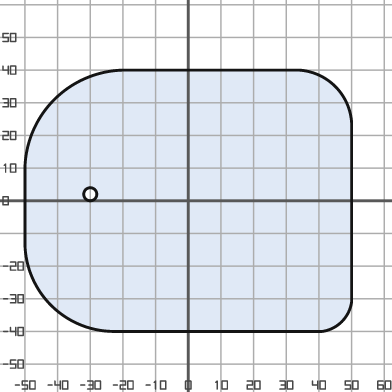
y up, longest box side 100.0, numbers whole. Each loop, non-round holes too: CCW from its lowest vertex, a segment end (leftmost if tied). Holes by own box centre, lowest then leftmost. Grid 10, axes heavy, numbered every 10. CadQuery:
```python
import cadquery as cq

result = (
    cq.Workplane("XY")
    .moveTo(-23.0, -40.0)
    .lineTo(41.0, -40.0)
    .threePointArc((47.0, -37.0), (50.0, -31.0))
    .lineTo(50.0, 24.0)
    .threePointArc((45.0, 35.0), (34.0, 40.0))
    .lineTo(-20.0, 40.0)
    .threePointArc((-41.0, 31.0), (-50.0, 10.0))
    .lineTo(-50.0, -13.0)
    .threePointArc((-42.0, -32.0), (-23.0, -40.0))
    .close()
    .moveTo(-30.0, 2.0)
    .circle(2.0)
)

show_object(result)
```